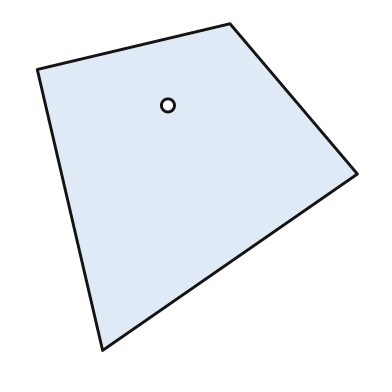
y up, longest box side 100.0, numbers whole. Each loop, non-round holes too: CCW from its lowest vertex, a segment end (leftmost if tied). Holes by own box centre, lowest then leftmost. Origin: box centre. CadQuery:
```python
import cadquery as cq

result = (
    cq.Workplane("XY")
    .moveTo(-29.0, -50.0)
    .lineTo(49.0, 4.0)
    .lineTo(10.0, 50.0)
    .lineTo(-49.0, 36.0)
    .close()
    .moveTo(-9.0, 25.0)
    .circle(2.0)
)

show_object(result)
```